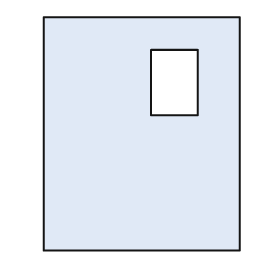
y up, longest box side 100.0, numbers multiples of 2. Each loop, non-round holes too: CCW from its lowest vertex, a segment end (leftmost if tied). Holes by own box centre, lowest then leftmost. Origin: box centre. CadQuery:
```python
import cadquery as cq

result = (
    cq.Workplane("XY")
    .moveTo(-42.0, -50.0)
    .lineTo(42.0, -50.0)
    .lineTo(42.0, 50.0)
    .lineTo(-42.0, 50.0)
    .close()
    .moveTo(4.0, 8.0)
    .lineTo(24.0, 8.0)
    .lineTo(24.0, 36.0)
    .lineTo(4.0, 36.0)
    .close()
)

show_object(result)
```